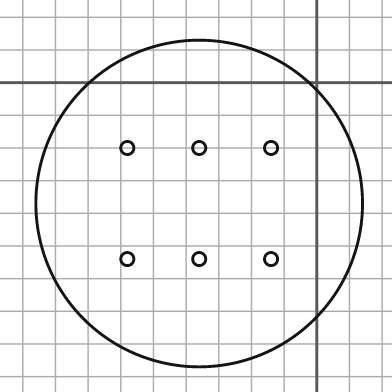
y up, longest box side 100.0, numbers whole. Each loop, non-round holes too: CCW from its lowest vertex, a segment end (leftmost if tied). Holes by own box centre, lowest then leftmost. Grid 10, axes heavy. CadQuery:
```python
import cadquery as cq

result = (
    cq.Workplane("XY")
    .moveTo(-36.0, -37.0)
    .circle(50.0)
    .moveTo(-58.0, -54.0)
    .circle(2.0)
    .moveTo(-36.0, -54.0)
    .circle(2.0)
    .moveTo(-14.0, -54.0)
    .circle(2.0)
    .moveTo(-58.0, -20.0)
    .circle(2.0)
    .moveTo(-36.0, -20.0)
    .circle(2.0)
    .moveTo(-14.0, -20.0)
    .circle(2.0)
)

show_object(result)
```